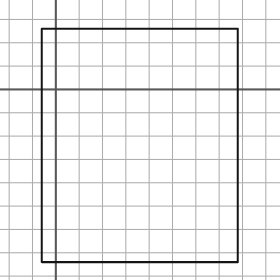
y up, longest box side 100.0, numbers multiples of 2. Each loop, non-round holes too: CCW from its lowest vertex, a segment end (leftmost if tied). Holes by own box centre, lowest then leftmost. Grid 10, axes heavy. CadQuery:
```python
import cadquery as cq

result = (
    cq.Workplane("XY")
    .moveTo(-6.0, -74.0)
    .lineTo(78.0, -74.0)
    .lineTo(78.0, 26.0)
    .lineTo(-6.0, 26.0)
    .close()
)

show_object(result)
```